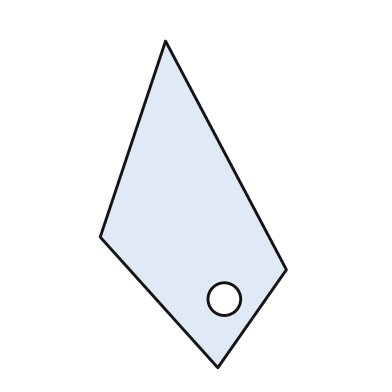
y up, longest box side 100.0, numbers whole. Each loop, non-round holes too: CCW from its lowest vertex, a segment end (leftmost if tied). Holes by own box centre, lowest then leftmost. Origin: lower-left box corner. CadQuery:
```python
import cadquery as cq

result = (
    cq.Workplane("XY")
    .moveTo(36.0, 0.0)
    .lineTo(57.0, 30.0)
    .lineTo(20.0, 100.0)
    .lineTo(0.0, 40.0)
    .close()
    .moveTo(38.0, 21.0)
    .circle(5.0)
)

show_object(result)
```